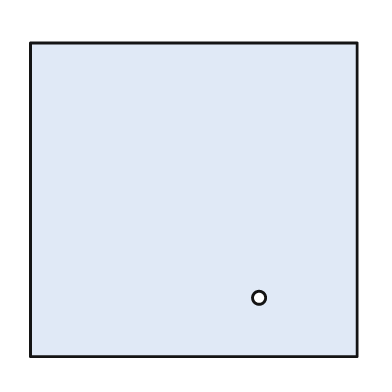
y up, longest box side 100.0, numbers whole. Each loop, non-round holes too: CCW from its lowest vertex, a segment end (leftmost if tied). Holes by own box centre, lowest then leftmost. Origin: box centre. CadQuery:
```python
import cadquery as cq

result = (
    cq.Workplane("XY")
    .moveTo(-50.0, -48.0)
    .lineTo(50.0, -48.0)
    .lineTo(50.0, 48.0)
    .lineTo(-50.0, 48.0)
    .close()
    .moveTo(20.0, -30.0)
    .circle(2.0)
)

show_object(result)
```